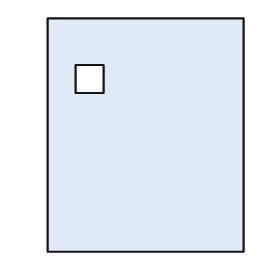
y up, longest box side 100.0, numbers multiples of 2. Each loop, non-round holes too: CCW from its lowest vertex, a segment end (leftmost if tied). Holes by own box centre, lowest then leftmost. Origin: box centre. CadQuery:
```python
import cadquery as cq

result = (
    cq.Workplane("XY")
    .moveTo(-42.0, -50.0)
    .lineTo(42.0, -50.0)
    .lineTo(42.0, 50.0)
    .lineTo(-42.0, 50.0)
    .close()
    .moveTo(-30.0, 18.0)
    .lineTo(-18.0, 18.0)
    .lineTo(-18.0, 30.0)
    .lineTo(-30.0, 30.0)
    .close()
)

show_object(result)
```